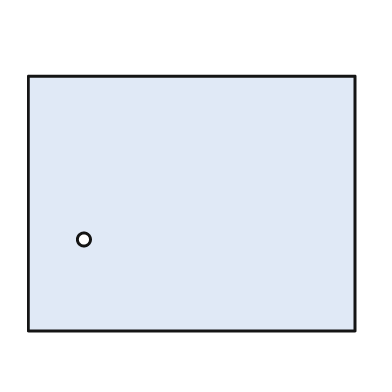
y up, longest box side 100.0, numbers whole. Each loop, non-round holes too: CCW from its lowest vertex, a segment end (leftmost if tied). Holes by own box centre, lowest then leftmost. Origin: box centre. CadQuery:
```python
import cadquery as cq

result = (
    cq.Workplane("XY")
    .moveTo(-50.0, -39.0)
    .lineTo(50.0, -39.0)
    .lineTo(50.0, 39.0)
    .lineTo(-50.0, 39.0)
    .close()
    .moveTo(-33.0, -11.0)
    .circle(2.0)
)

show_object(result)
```